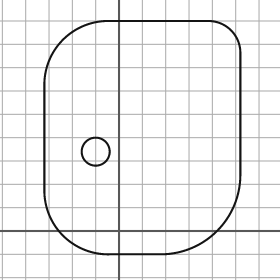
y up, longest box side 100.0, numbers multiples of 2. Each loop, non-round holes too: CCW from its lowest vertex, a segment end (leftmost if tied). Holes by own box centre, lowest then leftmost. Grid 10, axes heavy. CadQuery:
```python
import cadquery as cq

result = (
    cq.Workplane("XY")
    .moveTo(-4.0, -10.0)
    .lineTo(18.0, -10.0)
    .threePointArc((42.0, 0.0), (52.0, 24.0))
    .lineTo(52.0, 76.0)
    .threePointArc((48.0, 86.0), (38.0, 90.0))
    .lineTo(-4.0, 90.0)
    .threePointArc((-24.0, 82.0), (-32.0, 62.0))
    .lineTo(-32.0, 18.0)
    .threePointArc((-24.0, -2.0), (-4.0, -10.0))
    .close()
    .moveTo(-10.0, 34.0)
    .circle(6.0)
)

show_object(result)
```